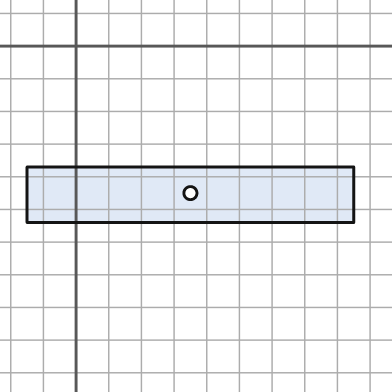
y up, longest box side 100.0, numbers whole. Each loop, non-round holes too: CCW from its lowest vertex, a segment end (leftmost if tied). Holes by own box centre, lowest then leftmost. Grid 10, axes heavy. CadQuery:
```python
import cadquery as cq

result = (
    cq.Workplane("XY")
    .moveTo(-15.0, -54.0)
    .lineTo(85.0, -54.0)
    .lineTo(85.0, -37.0)
    .lineTo(-15.0, -37.0)
    .close()
    .moveTo(35.0, -45.0)
    .circle(2.0)
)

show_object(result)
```